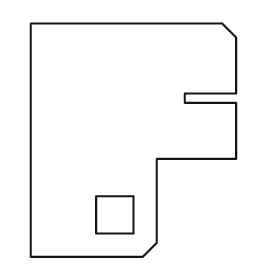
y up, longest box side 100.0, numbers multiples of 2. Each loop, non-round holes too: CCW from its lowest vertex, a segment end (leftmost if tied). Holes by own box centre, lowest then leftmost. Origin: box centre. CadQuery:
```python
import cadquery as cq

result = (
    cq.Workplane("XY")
    .moveTo(-44.0, -50.0)
    .lineTo(4.0, -50.0)
    .lineTo(10.0, -44.0)
    .lineTo(10.0, -8.0)
    .lineTo(44.0, -8.0)
    .lineTo(44.0, 16.0)
    .lineTo(22.0, 16.0)
    .lineTo(22.0, 20.0)
    .lineTo(44.0, 20.0)
    .lineTo(44.0, 44.0)
    .lineTo(38.0, 50.0)
    .lineTo(-44.0, 50.0)
    .close()
    .moveTo(-16.0, -40.0)
    .lineTo(0.0, -40.0)
    .lineTo(0.0, -24.0)
    .lineTo(-16.0, -24.0)
    .close()
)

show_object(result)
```